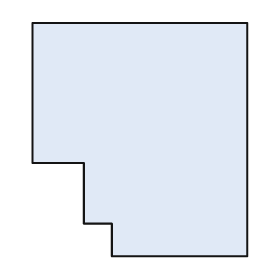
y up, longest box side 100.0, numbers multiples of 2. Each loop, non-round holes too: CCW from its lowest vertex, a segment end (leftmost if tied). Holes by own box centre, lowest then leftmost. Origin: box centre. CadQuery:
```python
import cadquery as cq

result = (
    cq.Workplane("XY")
    .moveTo(-12.0, -50.0)
    .lineTo(46.0, -50.0)
    .lineTo(46.0, 50.0)
    .lineTo(-46.0, 50.0)
    .lineTo(-46.0, -10.0)
    .lineTo(-24.0, -10.0)
    .lineTo(-24.0, -36.0)
    .lineTo(-12.0, -36.0)
    .close()
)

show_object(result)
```